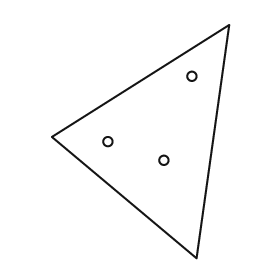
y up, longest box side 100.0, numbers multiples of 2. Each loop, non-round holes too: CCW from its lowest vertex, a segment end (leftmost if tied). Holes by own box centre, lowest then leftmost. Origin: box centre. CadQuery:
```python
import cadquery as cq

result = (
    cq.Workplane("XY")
    .moveTo(24.0, -50.0)
    .lineTo(38.0, 50.0)
    .lineTo(-38.0, 2.0)
    .close()
    .moveTo(10.0, -8.0)
    .circle(2.0)
    .moveTo(-14.0, 0.0)
    .circle(2.0)
    .moveTo(22.0, 28.0)
    .circle(2.0)
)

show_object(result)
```